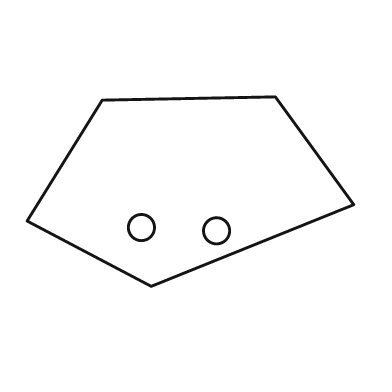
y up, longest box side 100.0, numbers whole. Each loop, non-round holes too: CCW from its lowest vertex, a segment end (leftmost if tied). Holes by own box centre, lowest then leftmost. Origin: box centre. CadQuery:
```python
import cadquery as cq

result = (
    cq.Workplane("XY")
    .moveTo(-12.0, -29.0)
    .lineTo(50.0, -4.0)
    .lineTo(26.0, 29.0)
    .lineTo(-27.0, 28.0)
    .lineTo(-50.0, -9.0)
    .close()
    .moveTo(8.0, -12.0)
    .circle(4.0)
    .moveTo(-15.0, -11.0)
    .circle(4.0)
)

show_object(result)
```